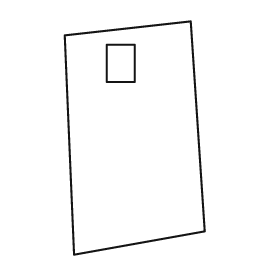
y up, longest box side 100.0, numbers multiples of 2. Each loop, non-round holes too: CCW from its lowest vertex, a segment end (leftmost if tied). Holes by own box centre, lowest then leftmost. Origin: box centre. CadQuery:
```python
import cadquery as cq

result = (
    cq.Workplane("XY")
    .moveTo(-26.0, -50.0)
    .lineTo(30.0, -40.0)
    .lineTo(24.0, 50.0)
    .lineTo(-30.0, 44.0)
    .close()
    .moveTo(-12.0, 24.0)
    .lineTo(0.0, 24.0)
    .lineTo(0.0, 40.0)
    .lineTo(-12.0, 40.0)
    .close()
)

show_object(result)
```